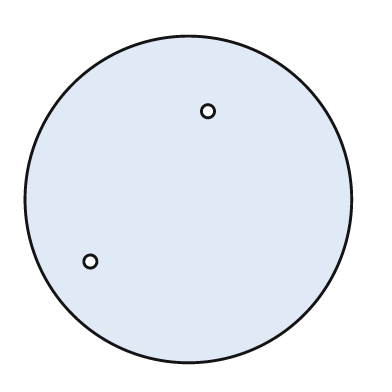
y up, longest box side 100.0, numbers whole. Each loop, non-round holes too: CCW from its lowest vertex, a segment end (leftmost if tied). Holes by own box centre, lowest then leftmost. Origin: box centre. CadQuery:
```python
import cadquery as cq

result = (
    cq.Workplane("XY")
    .moveTo(0.0, 0.0)
    .circle(50.0)
    .moveTo(-30.0, -19.0)
    .circle(2.0)
    .moveTo(6.0, 27.0)
    .circle(2.0)
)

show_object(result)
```